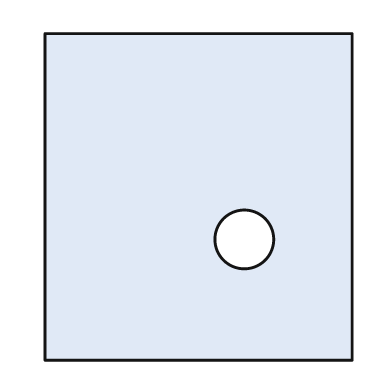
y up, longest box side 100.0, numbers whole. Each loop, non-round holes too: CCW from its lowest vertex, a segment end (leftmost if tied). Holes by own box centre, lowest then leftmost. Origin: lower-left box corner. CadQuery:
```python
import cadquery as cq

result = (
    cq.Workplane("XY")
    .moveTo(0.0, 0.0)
    .lineTo(94.0, 0.0)
    .lineTo(94.0, 100.0)
    .lineTo(0.0, 100.0)
    .close()
    .moveTo(61.0, 37.0)
    .circle(9.0)
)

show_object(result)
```